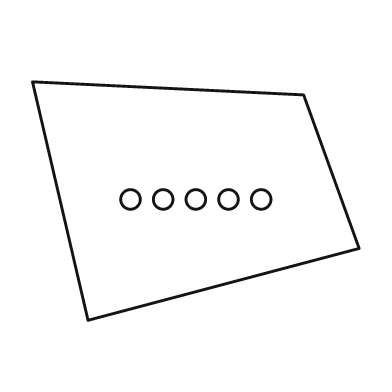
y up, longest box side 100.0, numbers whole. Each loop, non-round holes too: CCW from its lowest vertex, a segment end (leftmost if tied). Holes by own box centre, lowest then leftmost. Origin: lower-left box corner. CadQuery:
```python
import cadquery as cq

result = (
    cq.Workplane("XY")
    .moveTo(17.0, 0.0)
    .lineTo(100.0, 22.0)
    .lineTo(83.0, 69.0)
    .lineTo(0.0, 73.0)
    .close()
    .moveTo(30.0, 37.0)
    .circle(3.0)
    .moveTo(40.0, 37.0)
    .circle(3.0)
    .moveTo(50.0, 37.0)
    .circle(3.0)
    .moveTo(60.0, 37.0)
    .circle(3.0)
    .moveTo(70.0, 37.0)
    .circle(3.0)
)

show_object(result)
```